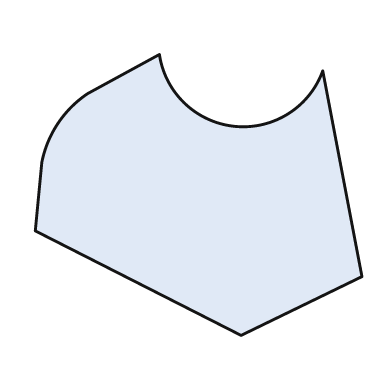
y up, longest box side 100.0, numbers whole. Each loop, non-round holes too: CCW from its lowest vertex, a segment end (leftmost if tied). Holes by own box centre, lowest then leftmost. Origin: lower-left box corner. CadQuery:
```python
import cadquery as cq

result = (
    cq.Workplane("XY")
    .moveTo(63.0, 0.0)
    .lineTo(100.0, 18.0)
    .lineTo(88.0, 81.0)
    .threePointArc((61.0, 64.0), (38.0, 86.0))
    .lineTo(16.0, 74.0)
    .threePointArc((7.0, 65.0), (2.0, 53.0))
    .lineTo(0.0, 32.0)
    .close()
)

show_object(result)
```